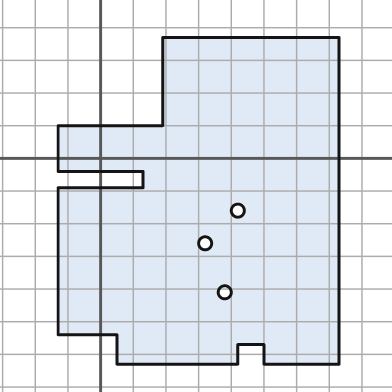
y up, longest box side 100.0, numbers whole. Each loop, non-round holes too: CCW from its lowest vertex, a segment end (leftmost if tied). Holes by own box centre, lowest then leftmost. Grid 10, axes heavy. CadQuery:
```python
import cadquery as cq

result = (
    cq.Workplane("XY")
    .moveTo(5.0, -63.0)
    .lineTo(42.0, -63.0)
    .lineTo(42.0, -57.0)
    .lineTo(50.0, -57.0)
    .lineTo(50.0, -63.0)
    .lineTo(73.0, -63.0)
    .lineTo(73.0, 37.0)
    .lineTo(19.0, 37.0)
    .lineTo(19.0, 10.0)
    .lineTo(-13.0, 10.0)
    .lineTo(-13.0, -4.0)
    .lineTo(13.0, -4.0)
    .lineTo(13.0, -9.0)
    .lineTo(-13.0, -9.0)
    .lineTo(-13.0, -54.0)
    .lineTo(5.0, -54.0)
    .close()
    .moveTo(38.0, -41.0)
    .circle(2.0)
    .moveTo(32.0, -26.0)
    .circle(2.0)
    .moveTo(42.0, -16.0)
    .circle(2.0)
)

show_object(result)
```